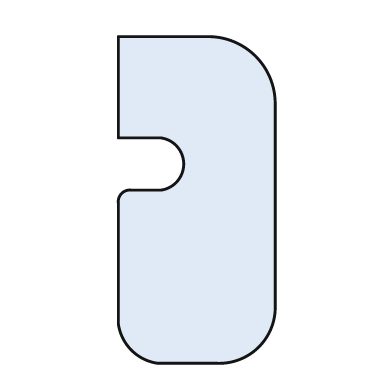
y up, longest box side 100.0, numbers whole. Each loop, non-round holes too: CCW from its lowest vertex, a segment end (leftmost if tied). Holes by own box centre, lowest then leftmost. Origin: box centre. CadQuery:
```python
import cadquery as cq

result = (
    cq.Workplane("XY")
    .moveTo(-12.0, -50.0)
    .lineTo(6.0, -50.0)
    .threePointArc((19.0, -45.0), (24.0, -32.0))
    .lineTo(24.0, 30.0)
    .threePointArc((18.0, 44.0), (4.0, 50.0))
    .lineTo(-24.0, 50.0)
    .lineTo(-24.0, 19.0)
    .lineTo(-11.0, 19.0)
    .threePointArc((-4.0, 11.0), (-11.0, 3.0))
    .lineTo(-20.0, 3.0)
    .threePointArc((-23.0, 2.0), (-24.0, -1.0))
    .lineTo(-24.0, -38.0)
    .threePointArc((-20.0, -46.0), (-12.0, -50.0))
    .close()
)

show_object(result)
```